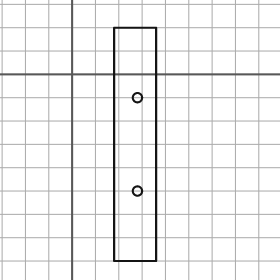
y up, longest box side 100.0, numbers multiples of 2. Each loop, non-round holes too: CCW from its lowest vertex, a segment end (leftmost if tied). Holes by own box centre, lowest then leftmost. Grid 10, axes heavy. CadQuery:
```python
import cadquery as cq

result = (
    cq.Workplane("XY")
    .moveTo(18.0, -80.0)
    .lineTo(36.0, -80.0)
    .lineTo(36.0, 20.0)
    .lineTo(18.0, 20.0)
    .close()
    .moveTo(28.0, -50.0)
    .circle(2.0)
    .moveTo(28.0, -10.0)
    .circle(2.0)
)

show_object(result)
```